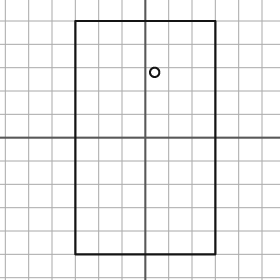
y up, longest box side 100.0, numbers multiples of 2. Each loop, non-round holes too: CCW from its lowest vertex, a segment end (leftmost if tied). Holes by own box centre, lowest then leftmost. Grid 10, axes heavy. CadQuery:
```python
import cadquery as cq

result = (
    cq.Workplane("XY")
    .moveTo(-30.0, -50.0)
    .lineTo(30.0, -50.0)
    .lineTo(30.0, 50.0)
    .lineTo(-30.0, 50.0)
    .close()
    .moveTo(4.0, 28.0)
    .circle(2.0)
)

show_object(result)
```